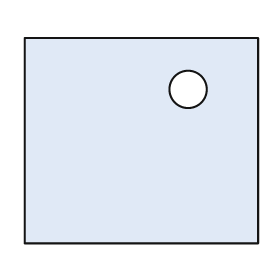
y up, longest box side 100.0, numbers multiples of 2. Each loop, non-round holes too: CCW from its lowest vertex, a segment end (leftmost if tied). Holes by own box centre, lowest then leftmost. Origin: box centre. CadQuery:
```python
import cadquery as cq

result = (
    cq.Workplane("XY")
    .moveTo(-50.0, -44.0)
    .lineTo(50.0, -44.0)
    .lineTo(50.0, 44.0)
    .lineTo(-50.0, 44.0)
    .close()
    .moveTo(20.0, 22.0)
    .circle(8.0)
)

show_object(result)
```